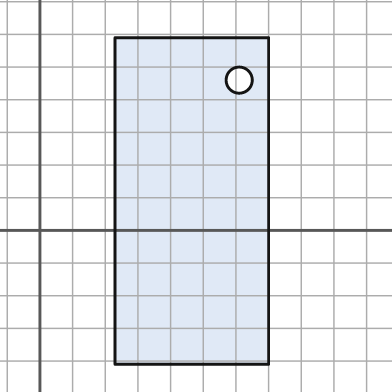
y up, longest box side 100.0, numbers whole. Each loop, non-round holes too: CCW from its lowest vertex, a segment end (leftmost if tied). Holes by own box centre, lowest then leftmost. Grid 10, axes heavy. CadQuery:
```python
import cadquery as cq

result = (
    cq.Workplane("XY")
    .moveTo(23.0, -41.0)
    .lineTo(70.0, -41.0)
    .lineTo(70.0, 59.0)
    .lineTo(23.0, 59.0)
    .close()
    .moveTo(61.0, 46.0)
    .circle(4.0)
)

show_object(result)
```